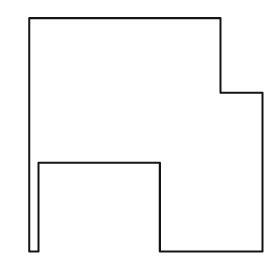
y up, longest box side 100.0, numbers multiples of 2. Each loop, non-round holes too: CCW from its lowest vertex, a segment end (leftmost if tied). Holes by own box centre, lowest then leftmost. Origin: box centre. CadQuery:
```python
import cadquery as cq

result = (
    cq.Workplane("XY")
    .moveTo(-50.0, -50.0)
    .lineTo(-46.0, -50.0)
    .lineTo(-46.0, -12.0)
    .lineTo(6.0, -12.0)
    .lineTo(6.0, -50.0)
    .lineTo(50.0, -50.0)
    .lineTo(50.0, 18.0)
    .lineTo(32.0, 18.0)
    .lineTo(32.0, 50.0)
    .lineTo(-50.0, 50.0)
    .close()
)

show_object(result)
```